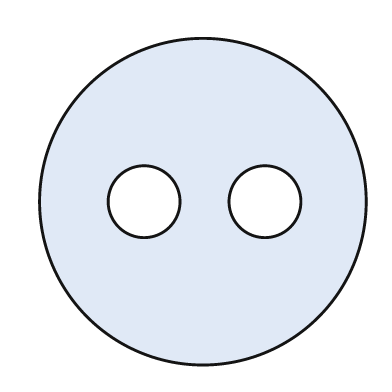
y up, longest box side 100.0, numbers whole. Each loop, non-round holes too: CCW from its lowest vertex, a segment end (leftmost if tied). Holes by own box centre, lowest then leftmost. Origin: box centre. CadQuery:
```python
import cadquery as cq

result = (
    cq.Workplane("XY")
    .moveTo(0.0, 0.0)
    .circle(50.0)
    .moveTo(-18.0, 0.0)
    .circle(11.0)
    .moveTo(19.0, 0.0)
    .circle(11.0)
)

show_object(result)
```